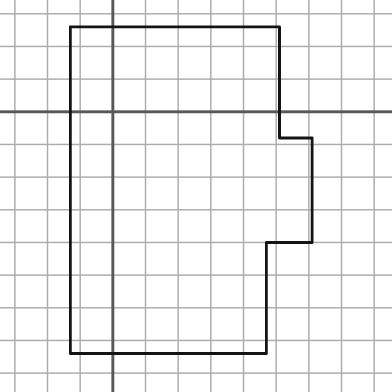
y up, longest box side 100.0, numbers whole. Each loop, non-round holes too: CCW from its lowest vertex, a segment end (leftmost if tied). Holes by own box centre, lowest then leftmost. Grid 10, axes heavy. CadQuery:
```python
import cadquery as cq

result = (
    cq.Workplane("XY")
    .moveTo(-13.0, -74.0)
    .lineTo(47.0, -74.0)
    .lineTo(47.0, -40.0)
    .lineTo(61.0, -40.0)
    .lineTo(61.0, -8.0)
    .lineTo(51.0, -8.0)
    .lineTo(51.0, 26.0)
    .lineTo(-13.0, 26.0)
    .close()
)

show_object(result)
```